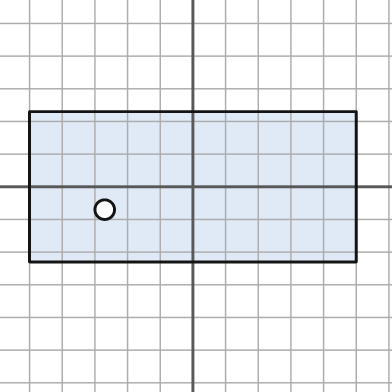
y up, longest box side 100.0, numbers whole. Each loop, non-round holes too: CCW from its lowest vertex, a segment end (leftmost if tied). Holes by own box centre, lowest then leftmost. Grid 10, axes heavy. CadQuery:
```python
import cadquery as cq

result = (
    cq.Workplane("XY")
    .moveTo(-50.0, -23.0)
    .lineTo(50.0, -23.0)
    .lineTo(50.0, 23.0)
    .lineTo(-50.0, 23.0)
    .close()
    .moveTo(-27.0, -7.0)
    .circle(3.0)
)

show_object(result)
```